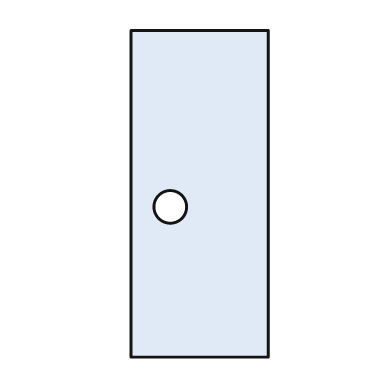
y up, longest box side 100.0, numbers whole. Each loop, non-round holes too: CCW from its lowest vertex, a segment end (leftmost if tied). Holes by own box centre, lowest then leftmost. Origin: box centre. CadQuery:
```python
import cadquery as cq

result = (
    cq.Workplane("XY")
    .moveTo(-21.0, -50.0)
    .lineTo(21.0, -50.0)
    .lineTo(21.0, 50.0)
    .lineTo(-21.0, 50.0)
    .close()
    .moveTo(-9.0, -4.0)
    .circle(5.0)
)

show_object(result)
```